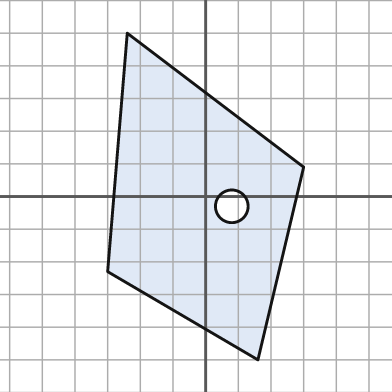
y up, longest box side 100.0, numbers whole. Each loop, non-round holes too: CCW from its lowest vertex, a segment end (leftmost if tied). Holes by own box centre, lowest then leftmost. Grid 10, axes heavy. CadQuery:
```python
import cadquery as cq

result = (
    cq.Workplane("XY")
    .moveTo(16.0, -50.0)
    .lineTo(30.0, 9.0)
    .lineTo(-24.0, 50.0)
    .lineTo(-30.0, -23.0)
    .close()
    .moveTo(8.0, -3.0)
    .circle(5.0)
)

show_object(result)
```